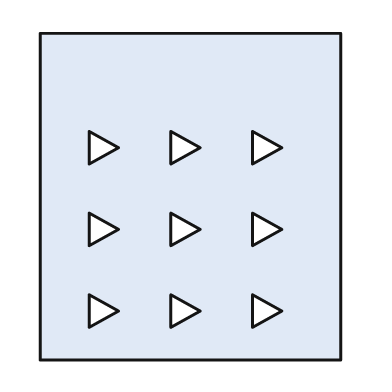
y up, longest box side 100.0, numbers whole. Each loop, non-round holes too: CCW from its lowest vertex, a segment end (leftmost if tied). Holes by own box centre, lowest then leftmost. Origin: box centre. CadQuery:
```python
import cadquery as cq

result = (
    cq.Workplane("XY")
    .moveTo(-46.0, -50.0)
    .lineTo(46.0, -50.0)
    .lineTo(46.0, 50.0)
    .lineTo(-46.0, 50.0)
    .close()
    .moveTo(-31.0, -40.0)
    .lineTo(-22.0, -35.0)
    .lineTo(-31.0, -30.0)
    .close()
    .moveTo(-6.0, -40.0)
    .lineTo(3.0, -35.0)
    .lineTo(-6.0, -30.0)
    .close()
    .moveTo(19.0, -40.0)
    .lineTo(28.0, -35.0)
    .lineTo(19.0, -30.0)
    .close()
    .moveTo(-31.0, -15.0)
    .lineTo(-22.0, -10.0)
    .lineTo(-31.0, -5.0)
    .close()
    .moveTo(-6.0, -15.0)
    .lineTo(3.0, -10.0)
    .lineTo(-6.0, -5.0)
    .close()
    .moveTo(19.0, -15.0)
    .lineTo(28.0, -10.0)
    .lineTo(19.0, -5.0)
    .close()
    .moveTo(-31.0, 10.0)
    .lineTo(-22.0, 15.0)
    .lineTo(-31.0, 20.0)
    .close()
    .moveTo(-6.0, 10.0)
    .lineTo(3.0, 15.0)
    .lineTo(-6.0, 20.0)
    .close()
    .moveTo(19.0, 10.0)
    .lineTo(28.0, 15.0)
    .lineTo(19.0, 20.0)
    .close()
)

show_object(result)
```